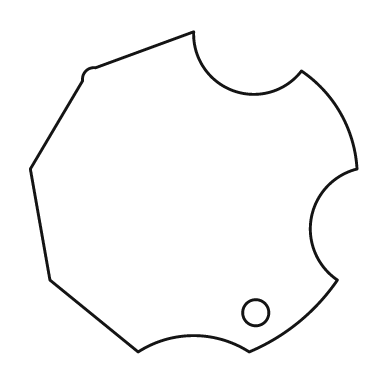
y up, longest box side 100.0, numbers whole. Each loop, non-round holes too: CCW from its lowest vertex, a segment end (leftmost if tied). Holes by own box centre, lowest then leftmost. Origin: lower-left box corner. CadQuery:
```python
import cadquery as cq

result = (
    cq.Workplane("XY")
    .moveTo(33.0, 0.0)
    .threePointArc((50.0, 5.0), (67.0, 0.0))
    .threePointArc((82.0, 9.0), (94.0, 22.0))
    .threePointArc((86.0, 41.0), (100.0, 56.0))
    .threePointArc((95.0, 73.0), (83.0, 86.0))
    .threePointArc((62.0, 80.0), (50.0, 98.0))
    .lineTo(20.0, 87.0)
    .threePointArc((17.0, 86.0), (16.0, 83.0))
    .lineTo(0.0, 56.0)
    .lineTo(6.0, 22.0)
    .close()
    .moveTo(69.0, 12.0)
    .circle(4.0)
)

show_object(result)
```